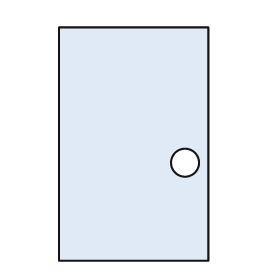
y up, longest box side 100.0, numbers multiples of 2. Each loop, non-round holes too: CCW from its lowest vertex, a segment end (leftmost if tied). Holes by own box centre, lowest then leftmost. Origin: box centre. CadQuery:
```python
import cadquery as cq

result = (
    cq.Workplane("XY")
    .moveTo(-32.0, -50.0)
    .lineTo(32.0, -50.0)
    .lineTo(32.0, 50.0)
    .lineTo(-32.0, 50.0)
    .close()
    .moveTo(22.0, -8.0)
    .circle(6.0)
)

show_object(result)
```